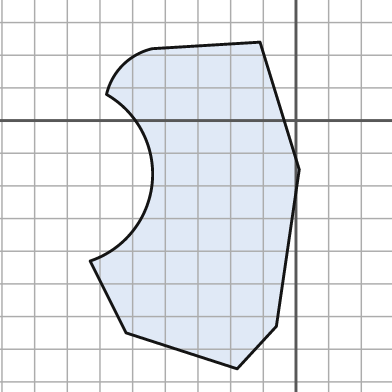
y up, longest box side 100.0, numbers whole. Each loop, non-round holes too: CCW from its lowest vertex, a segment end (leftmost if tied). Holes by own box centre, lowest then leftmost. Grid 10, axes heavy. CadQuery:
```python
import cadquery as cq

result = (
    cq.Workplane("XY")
    .moveTo(-18.0, -76.0)
    .lineTo(-6.0, -63.0)
    .lineTo(1.0, -15.0)
    .lineTo(-11.0, 24.0)
    .lineTo(-44.0, 22.0)
    .threePointArc((-53.0, 17.0), (-58.0, 8.0))
    .threePointArc((-44.0, -19.0), (-63.0, -43.0))
    .lineTo(-52.0, -65.0)
    .close()
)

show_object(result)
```